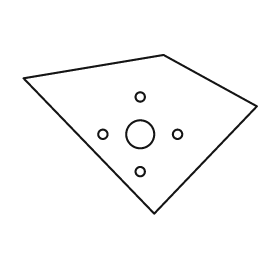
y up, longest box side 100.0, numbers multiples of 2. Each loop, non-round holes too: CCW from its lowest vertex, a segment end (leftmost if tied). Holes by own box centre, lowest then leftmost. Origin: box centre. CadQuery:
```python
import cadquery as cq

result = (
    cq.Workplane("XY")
    .moveTo(6.0, -34.0)
    .lineTo(50.0, 12.0)
    .lineTo(10.0, 34.0)
    .lineTo(-50.0, 24.0)
    .close()
    .moveTo(0.0, -16.0)
    .circle(2.0)
    .moveTo(-16.0, 0.0)
    .circle(2.0)
    .moveTo(0.0, 0.0)
    .circle(6.0)
    .moveTo(16.0, 0.0)
    .circle(2.0)
    .moveTo(0.0, 16.0)
    .circle(2.0)
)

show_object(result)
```